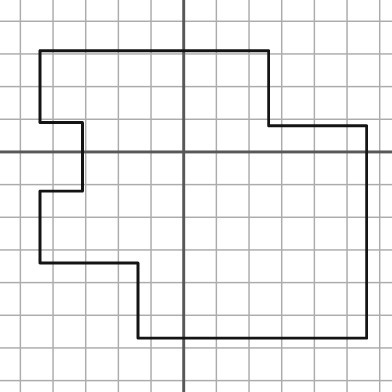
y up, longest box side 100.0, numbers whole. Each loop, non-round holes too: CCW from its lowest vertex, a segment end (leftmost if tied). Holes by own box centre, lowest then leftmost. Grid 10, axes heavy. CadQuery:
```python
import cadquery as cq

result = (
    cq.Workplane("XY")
    .moveTo(-14.0, -57.0)
    .lineTo(56.0, -57.0)
    .lineTo(56.0, 8.0)
    .lineTo(26.0, 8.0)
    .lineTo(26.0, 31.0)
    .lineTo(-44.0, 31.0)
    .lineTo(-44.0, 9.0)
    .lineTo(-31.0, 9.0)
    .lineTo(-31.0, -12.0)
    .lineTo(-44.0, -12.0)
    .lineTo(-44.0, -34.0)
    .lineTo(-14.0, -34.0)
    .close()
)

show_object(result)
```